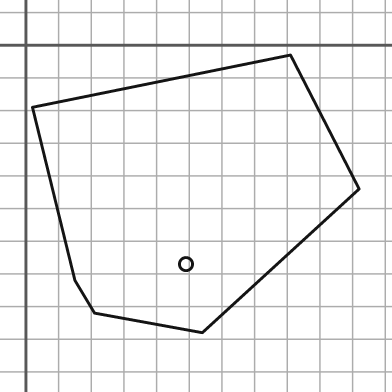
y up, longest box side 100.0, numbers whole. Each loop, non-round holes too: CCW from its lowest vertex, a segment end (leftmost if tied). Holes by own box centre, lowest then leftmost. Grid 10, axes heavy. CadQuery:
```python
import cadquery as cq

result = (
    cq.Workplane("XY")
    .moveTo(54.0, -88.0)
    .lineTo(102.0, -44.0)
    .lineTo(81.0, -3.0)
    .lineTo(2.0, -19.0)
    .lineTo(15.0, -72.0)
    .lineTo(21.0, -82.0)
    .close()
    .moveTo(49.0, -67.0)
    .circle(2.0)
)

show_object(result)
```